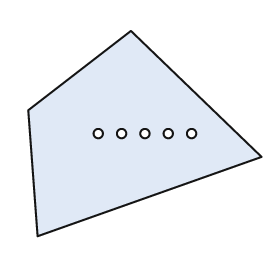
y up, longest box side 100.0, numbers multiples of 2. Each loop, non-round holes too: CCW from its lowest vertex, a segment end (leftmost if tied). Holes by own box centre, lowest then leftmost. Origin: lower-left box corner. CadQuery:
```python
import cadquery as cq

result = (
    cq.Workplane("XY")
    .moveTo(4.0, 0.0)
    .lineTo(100.0, 34.0)
    .lineTo(44.0, 88.0)
    .lineTo(0.0, 54.0)
    .close()
    .moveTo(30.0, 44.0)
    .circle(2.0)
    .moveTo(40.0, 44.0)
    .circle(2.0)
    .moveTo(50.0, 44.0)
    .circle(2.0)
    .moveTo(60.0, 44.0)
    .circle(2.0)
    .moveTo(70.0, 44.0)
    .circle(2.0)
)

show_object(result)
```